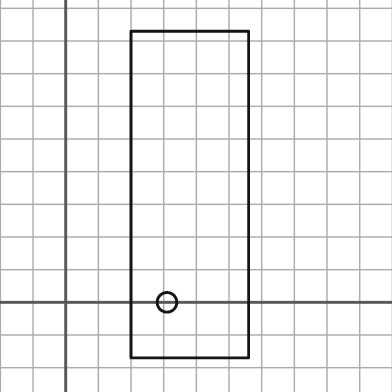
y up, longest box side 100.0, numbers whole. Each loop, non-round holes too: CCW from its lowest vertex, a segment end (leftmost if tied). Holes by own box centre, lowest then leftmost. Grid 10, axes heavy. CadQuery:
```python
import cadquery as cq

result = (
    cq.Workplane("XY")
    .moveTo(20.0, -17.0)
    .lineTo(56.0, -17.0)
    .lineTo(56.0, 83.0)
    .lineTo(20.0, 83.0)
    .close()
    .moveTo(31.0, 0.0)
    .circle(3.0)
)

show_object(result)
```